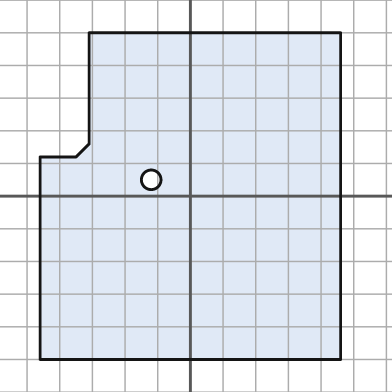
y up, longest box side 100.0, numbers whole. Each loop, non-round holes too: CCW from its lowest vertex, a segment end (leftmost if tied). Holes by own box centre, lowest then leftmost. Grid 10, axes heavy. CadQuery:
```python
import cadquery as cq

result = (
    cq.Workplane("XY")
    .moveTo(-46.0, -50.0)
    .lineTo(46.0, -50.0)
    .lineTo(46.0, 50.0)
    .lineTo(-31.0, 50.0)
    .lineTo(-31.0, 16.0)
    .lineTo(-35.0, 12.0)
    .lineTo(-46.0, 12.0)
    .close()
    .moveTo(-12.0, 5.0)
    .circle(3.0)
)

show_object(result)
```